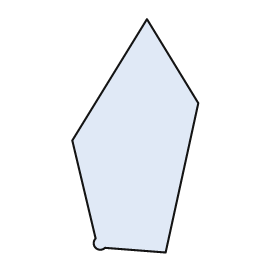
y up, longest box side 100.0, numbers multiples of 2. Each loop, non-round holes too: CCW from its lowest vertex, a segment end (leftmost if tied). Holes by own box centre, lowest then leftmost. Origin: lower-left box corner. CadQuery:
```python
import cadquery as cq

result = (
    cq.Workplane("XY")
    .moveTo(40.0, 0.0)
    .lineTo(54.0, 64.0)
    .lineTo(32.0, 100.0)
    .lineTo(0.0, 48.0)
    .lineTo(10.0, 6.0)
    .threePointArc((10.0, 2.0), (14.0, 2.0))
    .close()
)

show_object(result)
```